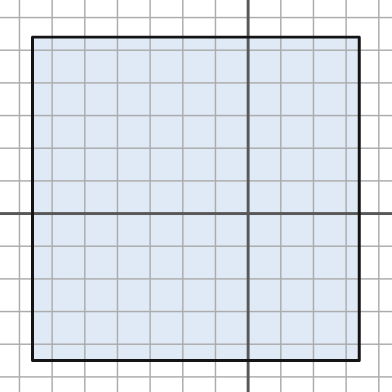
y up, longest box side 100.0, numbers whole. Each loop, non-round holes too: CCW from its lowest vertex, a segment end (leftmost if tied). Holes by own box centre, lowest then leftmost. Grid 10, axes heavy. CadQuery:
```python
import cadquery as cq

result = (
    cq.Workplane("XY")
    .moveTo(-66.0, -45.0)
    .lineTo(34.0, -45.0)
    .lineTo(34.0, 54.0)
    .lineTo(-66.0, 54.0)
    .close()
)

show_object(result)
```